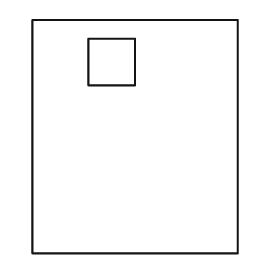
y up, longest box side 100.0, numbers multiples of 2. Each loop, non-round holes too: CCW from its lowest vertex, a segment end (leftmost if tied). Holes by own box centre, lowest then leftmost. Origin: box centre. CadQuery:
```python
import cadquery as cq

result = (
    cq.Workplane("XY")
    .moveTo(-44.0, -50.0)
    .lineTo(44.0, -50.0)
    .lineTo(44.0, 50.0)
    .lineTo(-44.0, 50.0)
    .close()
    .moveTo(-20.0, 22.0)
    .lineTo(0.0, 22.0)
    .lineTo(0.0, 42.0)
    .lineTo(-20.0, 42.0)
    .close()
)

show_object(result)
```